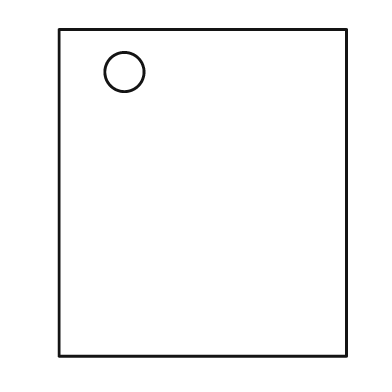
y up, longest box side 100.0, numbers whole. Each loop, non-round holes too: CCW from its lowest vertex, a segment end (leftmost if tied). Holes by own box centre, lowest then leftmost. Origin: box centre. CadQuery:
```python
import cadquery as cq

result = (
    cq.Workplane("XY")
    .moveTo(-44.0, -50.0)
    .lineTo(44.0, -50.0)
    .lineTo(44.0, 50.0)
    .lineTo(-44.0, 50.0)
    .close()
    .moveTo(-24.0, 37.0)
    .circle(6.0)
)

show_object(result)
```